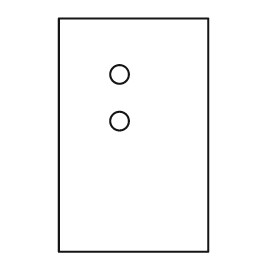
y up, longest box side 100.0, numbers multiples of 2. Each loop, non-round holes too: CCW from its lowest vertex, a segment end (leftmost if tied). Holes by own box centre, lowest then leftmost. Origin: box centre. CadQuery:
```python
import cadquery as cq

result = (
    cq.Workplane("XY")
    .moveTo(-32.0, -50.0)
    .lineTo(32.0, -50.0)
    .lineTo(32.0, 50.0)
    .lineTo(-32.0, 50.0)
    .close()
    .moveTo(-6.0, 6.0)
    .circle(4.0)
    .moveTo(-6.0, 26.0)
    .circle(4.0)
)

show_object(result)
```